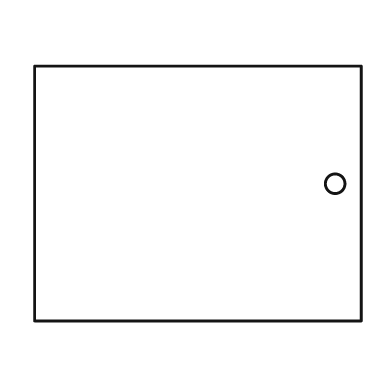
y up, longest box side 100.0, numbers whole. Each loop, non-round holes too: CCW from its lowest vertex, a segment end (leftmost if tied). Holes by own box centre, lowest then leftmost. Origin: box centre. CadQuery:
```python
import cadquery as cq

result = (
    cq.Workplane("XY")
    .moveTo(-50.0, -39.0)
    .lineTo(50.0, -39.0)
    .lineTo(50.0, 39.0)
    .lineTo(-50.0, 39.0)
    .close()
    .moveTo(42.0, 3.0)
    .circle(3.0)
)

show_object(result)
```